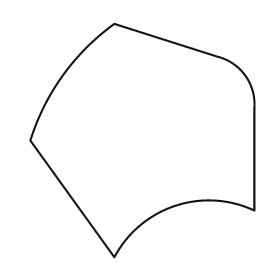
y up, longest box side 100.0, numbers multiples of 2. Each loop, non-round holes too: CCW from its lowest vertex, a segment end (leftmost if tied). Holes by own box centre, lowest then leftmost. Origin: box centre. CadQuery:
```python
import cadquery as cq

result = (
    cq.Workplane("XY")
    .moveTo(-12.0, -50.0)
    .threePointArc((14.0, -28.0), (48.0, -30.0))
    .lineTo(48.0, 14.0)
    .threePointArc((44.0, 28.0), (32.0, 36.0))
    .lineTo(-12.0, 50.0)
    .threePointArc((-34.0, 28.0), (-48.0, 0.0))
    .close()
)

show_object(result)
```